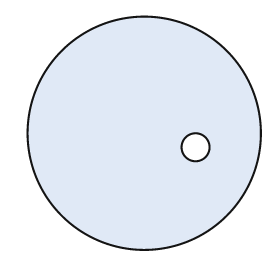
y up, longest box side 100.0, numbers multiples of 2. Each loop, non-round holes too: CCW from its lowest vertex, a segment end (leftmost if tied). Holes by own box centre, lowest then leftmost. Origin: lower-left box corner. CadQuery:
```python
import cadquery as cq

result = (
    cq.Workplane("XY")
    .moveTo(50.0, 50.0)
    .circle(50.0)
    .moveTo(72.0, 44.0)
    .circle(6.0)
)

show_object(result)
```